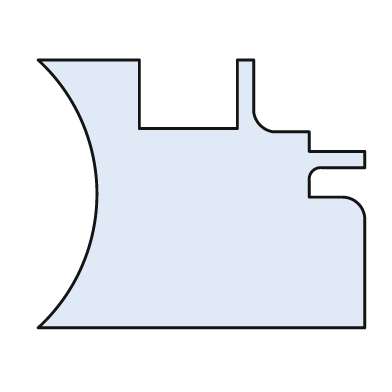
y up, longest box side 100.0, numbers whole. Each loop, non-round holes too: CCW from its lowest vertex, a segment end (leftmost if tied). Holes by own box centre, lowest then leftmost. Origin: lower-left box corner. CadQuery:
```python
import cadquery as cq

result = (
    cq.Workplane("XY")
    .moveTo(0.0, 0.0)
    .lineTo(100.0, 0.0)
    .lineTo(100.0, 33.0)
    .threePointArc((98.0, 38.0), (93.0, 40.0))
    .lineTo(83.0, 40.0)
    .lineTo(83.0, 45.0)
    .threePointArc((84.0, 48.0), (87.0, 49.0))
    .lineTo(100.0, 49.0)
    .lineTo(100.0, 54.0)
    .lineTo(83.0, 54.0)
    .lineTo(83.0, 60.0)
    .lineTo(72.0, 60.0)
    .threePointArc((68.0, 62.0), (66.0, 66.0))
    .lineTo(66.0, 82.0)
    .lineTo(61.0, 82.0)
    .lineTo(61.0, 61.0)
    .lineTo(31.0, 61.0)
    .lineTo(31.0, 82.0)
    .lineTo(0.0, 82.0)
    .threePointArc((18.0, 41.0), (0.0, 0.0))
    .close()
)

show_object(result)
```